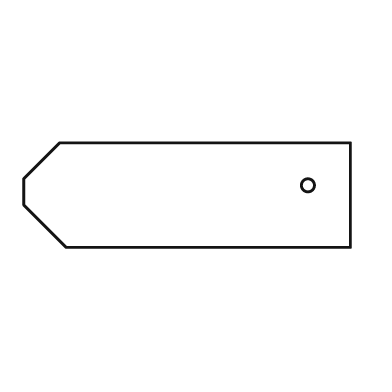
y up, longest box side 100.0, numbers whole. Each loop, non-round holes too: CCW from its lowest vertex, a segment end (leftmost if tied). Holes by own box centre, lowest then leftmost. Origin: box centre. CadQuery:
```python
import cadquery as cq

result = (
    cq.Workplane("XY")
    .moveTo(-37.0, -16.0)
    .lineTo(50.0, -16.0)
    .lineTo(50.0, 16.0)
    .lineTo(-39.0, 16.0)
    .lineTo(-50.0, 5.0)
    .lineTo(-50.0, -3.0)
    .close()
    .moveTo(37.0, 3.0)
    .circle(2.0)
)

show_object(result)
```